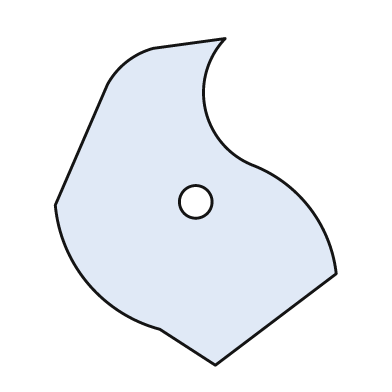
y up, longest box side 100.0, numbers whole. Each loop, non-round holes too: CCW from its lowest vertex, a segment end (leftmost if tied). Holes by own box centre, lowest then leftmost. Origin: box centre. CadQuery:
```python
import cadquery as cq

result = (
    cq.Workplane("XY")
    .moveTo(6.0, -50.0)
    .lineTo(43.0, -22.0)
    .threePointArc((35.0, -2.0), (18.0, 11.0))
    .threePointArc((3.0, 28.0), (9.0, 50.0))
    .lineTo(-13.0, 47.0)
    .threePointArc((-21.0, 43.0), (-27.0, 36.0))
    .lineTo(-43.0, -1.0)
    .threePointArc((-33.0, -25.0), (-11.0, -39.0))
    .close()
    .moveTo(0.0, 0.0)
    .circle(5.0)
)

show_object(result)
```